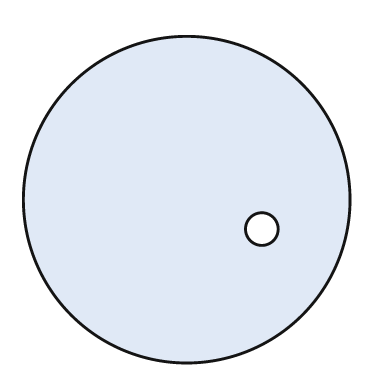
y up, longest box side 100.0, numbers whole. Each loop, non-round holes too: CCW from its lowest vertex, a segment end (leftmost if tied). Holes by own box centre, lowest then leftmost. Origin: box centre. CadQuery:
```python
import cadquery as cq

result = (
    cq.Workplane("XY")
    .moveTo(0.0, 0.0)
    .circle(50.0)
    .moveTo(23.0, -9.0)
    .circle(5.0)
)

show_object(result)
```